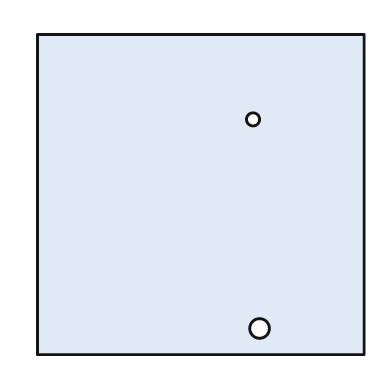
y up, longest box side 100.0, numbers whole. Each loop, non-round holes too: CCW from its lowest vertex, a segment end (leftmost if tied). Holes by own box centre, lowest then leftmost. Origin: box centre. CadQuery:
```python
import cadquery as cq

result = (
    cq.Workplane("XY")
    .moveTo(-50.0, -49.0)
    .lineTo(50.0, -49.0)
    .lineTo(50.0, 49.0)
    .lineTo(-50.0, 49.0)
    .close()
    .moveTo(18.0, -41.0)
    .circle(3.0)
    .moveTo(16.0, 23.0)
    .circle(2.0)
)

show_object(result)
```